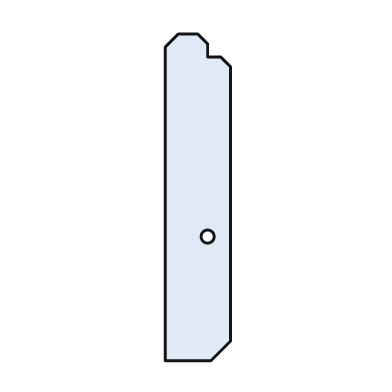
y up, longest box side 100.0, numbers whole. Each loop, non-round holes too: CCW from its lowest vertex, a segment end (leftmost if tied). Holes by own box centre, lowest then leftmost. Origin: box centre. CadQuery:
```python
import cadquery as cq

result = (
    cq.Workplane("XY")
    .moveTo(-10.0, -50.0)
    .lineTo(4.0, -50.0)
    .lineTo(10.0, -44.0)
    .lineTo(10.0, 40.0)
    .lineTo(7.0, 43.0)
    .lineTo(3.0, 43.0)
    .lineTo(3.0, 47.0)
    .lineTo(0.0, 50.0)
    .lineTo(-6.0, 50.0)
    .lineTo(-10.0, 46.0)
    .close()
    .moveTo(3.0, -12.0)
    .circle(2.0)
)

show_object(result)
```